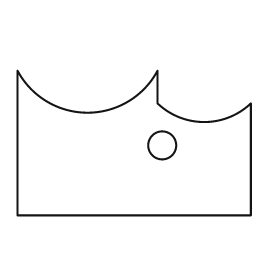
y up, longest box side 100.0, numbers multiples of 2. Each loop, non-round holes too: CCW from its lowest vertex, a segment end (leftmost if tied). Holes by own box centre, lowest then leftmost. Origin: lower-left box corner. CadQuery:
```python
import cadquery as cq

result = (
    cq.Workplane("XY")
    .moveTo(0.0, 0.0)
    .lineTo(100.0, 0.0)
    .lineTo(100.0, 48.0)
    .threePointArc((80.0, 40.0), (60.0, 48.0))
    .lineTo(60.0, 62.0)
    .threePointArc((30.0, 44.0), (0.0, 62.0))
    .close()
    .moveTo(62.0, 30.0)
    .circle(6.0)
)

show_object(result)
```